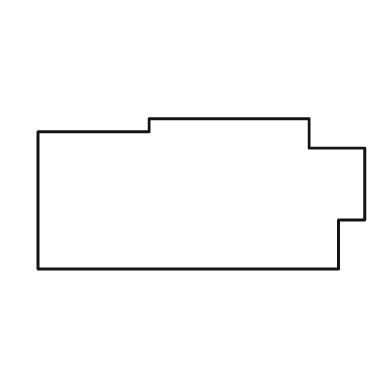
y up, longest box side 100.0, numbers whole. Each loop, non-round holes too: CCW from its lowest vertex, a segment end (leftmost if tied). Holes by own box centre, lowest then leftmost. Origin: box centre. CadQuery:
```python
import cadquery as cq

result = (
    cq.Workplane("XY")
    .moveTo(-50.0, -23.0)
    .lineTo(42.0, -23.0)
    .lineTo(42.0, -8.0)
    .lineTo(50.0, -8.0)
    .lineTo(50.0, 14.0)
    .lineTo(33.0, 14.0)
    .lineTo(33.0, 23.0)
    .lineTo(-16.0, 23.0)
    .lineTo(-16.0, 19.0)
    .lineTo(-50.0, 19.0)
    .close()
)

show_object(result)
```